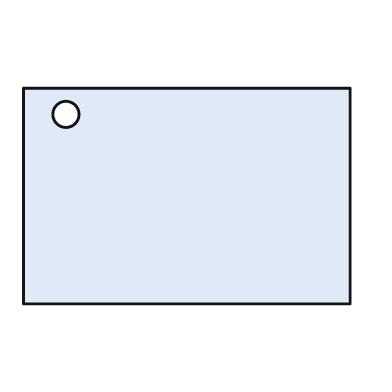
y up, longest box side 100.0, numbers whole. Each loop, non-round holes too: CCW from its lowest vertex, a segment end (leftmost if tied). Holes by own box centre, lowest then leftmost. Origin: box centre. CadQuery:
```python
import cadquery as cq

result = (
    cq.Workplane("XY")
    .moveTo(-50.0, -33.0)
    .lineTo(50.0, -33.0)
    .lineTo(50.0, 33.0)
    .lineTo(-50.0, 33.0)
    .close()
    .moveTo(-37.0, 25.0)
    .circle(4.0)
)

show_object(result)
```